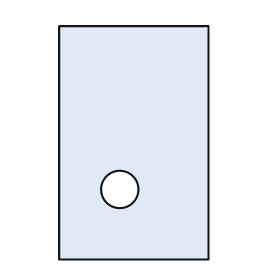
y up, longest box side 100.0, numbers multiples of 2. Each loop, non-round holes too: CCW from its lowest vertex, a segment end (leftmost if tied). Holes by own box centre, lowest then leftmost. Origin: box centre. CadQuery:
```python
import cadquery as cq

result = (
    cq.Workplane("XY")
    .moveTo(-32.0, -50.0)
    .lineTo(32.0, -50.0)
    .lineTo(32.0, 50.0)
    .lineTo(-32.0, 50.0)
    .close()
    .moveTo(-6.0, -20.0)
    .circle(8.0)
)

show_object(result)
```